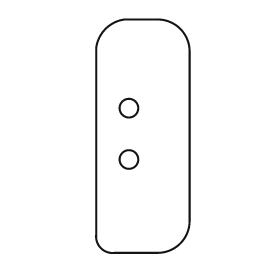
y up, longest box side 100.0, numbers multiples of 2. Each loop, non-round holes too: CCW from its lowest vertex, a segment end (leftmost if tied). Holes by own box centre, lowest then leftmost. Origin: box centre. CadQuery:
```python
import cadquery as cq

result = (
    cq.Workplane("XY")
    .moveTo(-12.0, -50.0)
    .lineTo(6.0, -50.0)
    .threePointArc((16.0, -46.0), (20.0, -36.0))
    .lineTo(20.0, 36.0)
    .threePointArc((16.0, 46.0), (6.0, 50.0))
    .lineTo(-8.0, 50.0)
    .threePointArc((-16.0, 46.0), (-20.0, 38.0))
    .lineTo(-20.0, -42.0)
    .threePointArc((-18.0, -48.0), (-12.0, -50.0))
    .close()
    .moveTo(-6.0, -10.0)
    .circle(4.0)
    .moveTo(-6.0, 12.0)
    .circle(4.0)
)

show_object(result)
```